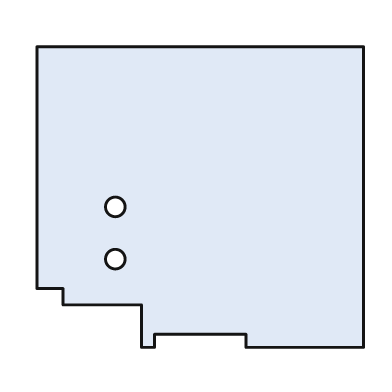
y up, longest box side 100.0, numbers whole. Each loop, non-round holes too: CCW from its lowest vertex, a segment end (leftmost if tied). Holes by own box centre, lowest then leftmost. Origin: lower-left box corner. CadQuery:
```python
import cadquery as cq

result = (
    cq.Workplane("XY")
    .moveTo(32.0, 0.0)
    .lineTo(36.0, 0.0)
    .lineTo(36.0, 4.0)
    .lineTo(64.0, 4.0)
    .lineTo(64.0, 0.0)
    .lineTo(100.0, 0.0)
    .lineTo(100.0, 92.0)
    .lineTo(0.0, 92.0)
    .lineTo(0.0, 18.0)
    .lineTo(8.0, 18.0)
    .lineTo(8.0, 13.0)
    .lineTo(32.0, 13.0)
    .close()
    .moveTo(24.0, 27.0)
    .circle(3.0)
    .moveTo(24.0, 43.0)
    .circle(3.0)
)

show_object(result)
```